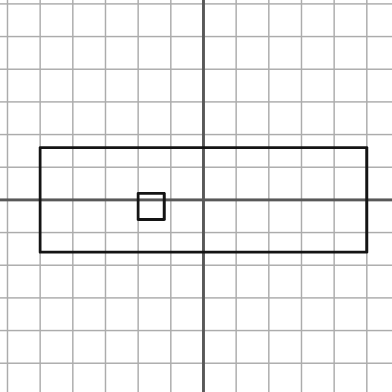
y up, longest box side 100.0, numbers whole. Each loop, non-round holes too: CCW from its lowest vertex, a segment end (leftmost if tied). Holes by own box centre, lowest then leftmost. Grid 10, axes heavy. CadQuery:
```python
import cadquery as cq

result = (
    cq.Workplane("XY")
    .moveTo(-50.0, -16.0)
    .lineTo(50.0, -16.0)
    .lineTo(50.0, 16.0)
    .lineTo(-50.0, 16.0)
    .close()
    .moveTo(-20.0, -6.0)
    .lineTo(-12.0, -6.0)
    .lineTo(-12.0, 2.0)
    .lineTo(-20.0, 2.0)
    .close()
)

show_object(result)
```